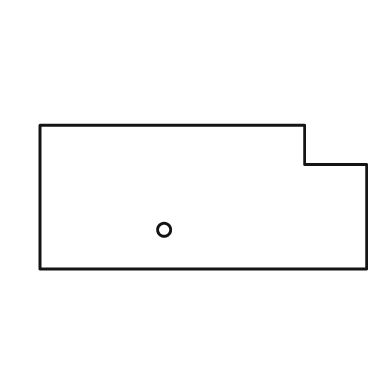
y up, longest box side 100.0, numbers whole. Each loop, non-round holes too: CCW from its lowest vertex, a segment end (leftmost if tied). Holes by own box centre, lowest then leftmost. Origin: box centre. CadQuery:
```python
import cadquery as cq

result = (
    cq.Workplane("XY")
    .moveTo(-50.0, -22.0)
    .lineTo(50.0, -22.0)
    .lineTo(50.0, 10.0)
    .lineTo(31.0, 10.0)
    .lineTo(31.0, 22.0)
    .lineTo(-50.0, 22.0)
    .close()
    .moveTo(-12.0, -10.0)
    .circle(2.0)
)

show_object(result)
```